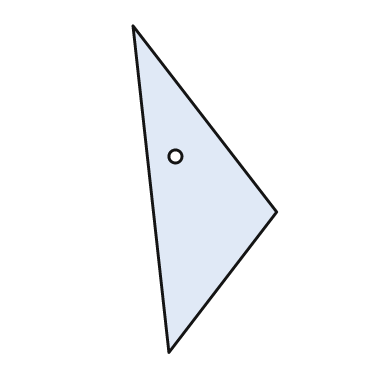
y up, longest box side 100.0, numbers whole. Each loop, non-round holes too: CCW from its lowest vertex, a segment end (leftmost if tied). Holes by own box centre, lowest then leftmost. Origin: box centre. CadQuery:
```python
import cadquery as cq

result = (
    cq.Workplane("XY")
    .moveTo(-11.0, -50.0)
    .lineTo(22.0, -7.0)
    .lineTo(-22.0, 50.0)
    .close()
    .moveTo(-9.0, 10.0)
    .circle(2.0)
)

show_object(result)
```